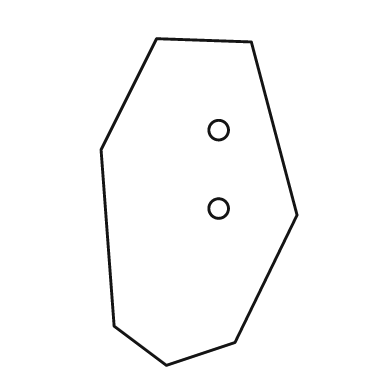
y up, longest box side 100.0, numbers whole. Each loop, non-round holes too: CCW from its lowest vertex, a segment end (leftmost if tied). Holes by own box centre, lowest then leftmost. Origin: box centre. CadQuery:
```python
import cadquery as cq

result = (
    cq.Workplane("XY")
    .moveTo(-10.0, -50.0)
    .lineTo(11.0, -43.0)
    .lineTo(30.0, -4.0)
    .lineTo(16.0, 49.0)
    .lineTo(-13.0, 50.0)
    .lineTo(-30.0, 16.0)
    .lineTo(-26.0, -38.0)
    .close()
    .moveTo(6.0, -2.0)
    .circle(3.0)
    .moveTo(6.0, 22.0)
    .circle(3.0)
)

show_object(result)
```